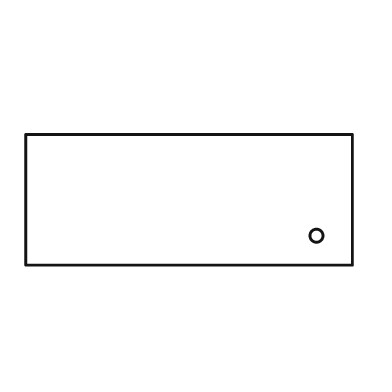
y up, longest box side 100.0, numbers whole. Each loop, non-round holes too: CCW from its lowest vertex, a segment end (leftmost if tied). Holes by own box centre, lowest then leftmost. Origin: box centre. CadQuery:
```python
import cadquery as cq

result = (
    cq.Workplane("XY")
    .moveTo(-50.0, -20.0)
    .lineTo(50.0, -20.0)
    .lineTo(50.0, 20.0)
    .lineTo(-50.0, 20.0)
    .close()
    .moveTo(39.0, -11.0)
    .circle(2.0)
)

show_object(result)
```